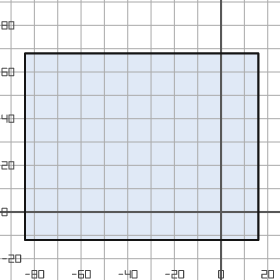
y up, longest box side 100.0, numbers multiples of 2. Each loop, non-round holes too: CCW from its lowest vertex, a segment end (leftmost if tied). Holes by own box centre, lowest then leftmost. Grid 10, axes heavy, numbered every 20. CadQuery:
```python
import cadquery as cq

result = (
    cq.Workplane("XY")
    .moveTo(-84.0, -12.0)
    .lineTo(16.0, -12.0)
    .lineTo(16.0, 68.0)
    .lineTo(-84.0, 68.0)
    .close()
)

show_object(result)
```